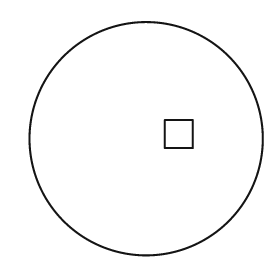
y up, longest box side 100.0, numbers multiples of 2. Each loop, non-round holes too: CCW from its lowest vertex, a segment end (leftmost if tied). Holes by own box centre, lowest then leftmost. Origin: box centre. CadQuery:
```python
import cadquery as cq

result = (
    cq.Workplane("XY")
    .moveTo(0.0, 0.0)
    .circle(50.0)
    .moveTo(8.0, -4.0)
    .lineTo(20.0, -4.0)
    .lineTo(20.0, 8.0)
    .lineTo(8.0, 8.0)
    .close()
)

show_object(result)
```